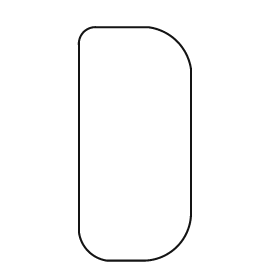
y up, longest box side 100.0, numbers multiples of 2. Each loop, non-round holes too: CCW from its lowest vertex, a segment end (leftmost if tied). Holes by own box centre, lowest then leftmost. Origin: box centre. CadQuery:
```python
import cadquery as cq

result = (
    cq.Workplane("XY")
    .moveTo(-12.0, -50.0)
    .lineTo(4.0, -50.0)
    .threePointArc((18.0, -44.0), (24.0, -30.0))
    .lineTo(24.0, 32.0)
    .threePointArc((18.0, 44.0), (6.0, 50.0))
    .lineTo(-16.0, 50.0)
    .threePointArc((-22.0, 48.0), (-24.0, 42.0))
    .lineTo(-24.0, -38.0)
    .threePointArc((-20.0, -46.0), (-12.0, -50.0))
    .close()
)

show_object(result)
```